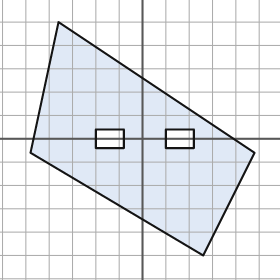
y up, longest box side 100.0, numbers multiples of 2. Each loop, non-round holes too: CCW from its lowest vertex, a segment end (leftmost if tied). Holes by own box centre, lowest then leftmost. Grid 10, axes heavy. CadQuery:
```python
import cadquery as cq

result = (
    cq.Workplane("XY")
    .moveTo(26.0, -50.0)
    .lineTo(48.0, -6.0)
    .lineTo(-36.0, 50.0)
    .lineTo(-48.0, -6.0)
    .close()
    .moveTo(-20.0, -4.0)
    .lineTo(-8.0, -4.0)
    .lineTo(-8.0, 4.0)
    .lineTo(-20.0, 4.0)
    .close()
    .moveTo(10.0, -4.0)
    .lineTo(22.0, -4.0)
    .lineTo(22.0, 4.0)
    .lineTo(10.0, 4.0)
    .close()
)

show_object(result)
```